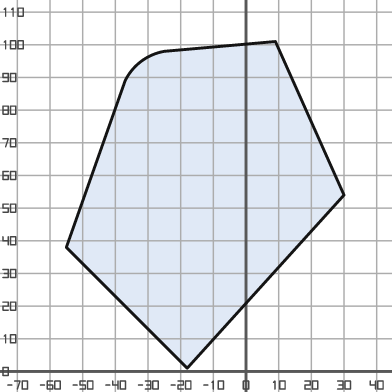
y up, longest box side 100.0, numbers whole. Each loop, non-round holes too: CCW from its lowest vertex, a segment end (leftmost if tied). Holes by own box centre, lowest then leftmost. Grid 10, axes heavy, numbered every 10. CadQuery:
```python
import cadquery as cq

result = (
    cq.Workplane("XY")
    .moveTo(-18.0, 1.0)
    .lineTo(30.0, 54.0)
    .lineTo(9.0, 101.0)
    .lineTo(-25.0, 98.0)
    .threePointArc((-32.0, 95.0), (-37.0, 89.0))
    .lineTo(-55.0, 38.0)
    .close()
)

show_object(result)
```